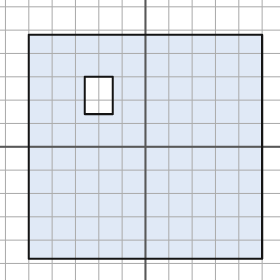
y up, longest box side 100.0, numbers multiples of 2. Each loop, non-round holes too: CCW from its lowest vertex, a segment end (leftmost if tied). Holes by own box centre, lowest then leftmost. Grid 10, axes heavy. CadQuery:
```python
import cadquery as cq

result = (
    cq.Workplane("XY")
    .moveTo(-50.0, -48.0)
    .lineTo(50.0, -48.0)
    .lineTo(50.0, 48.0)
    .lineTo(-50.0, 48.0)
    .close()
    .moveTo(-26.0, 14.0)
    .lineTo(-14.0, 14.0)
    .lineTo(-14.0, 30.0)
    .lineTo(-26.0, 30.0)
    .close()
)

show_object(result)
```